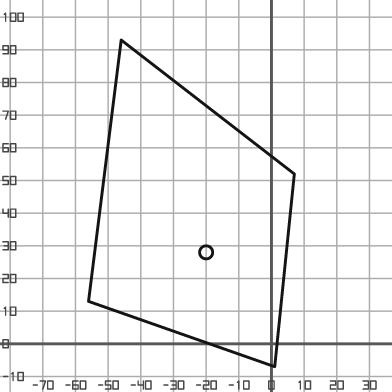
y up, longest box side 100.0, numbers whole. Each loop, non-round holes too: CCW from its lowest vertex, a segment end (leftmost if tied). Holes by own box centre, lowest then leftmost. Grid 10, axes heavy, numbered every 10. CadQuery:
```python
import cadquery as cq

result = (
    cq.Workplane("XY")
    .moveTo(1.0, -7.0)
    .lineTo(7.0, 52.0)
    .lineTo(-46.0, 93.0)
    .lineTo(-56.0, 13.0)
    .close()
    .moveTo(-20.0, 28.0)
    .circle(2.0)
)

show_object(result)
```